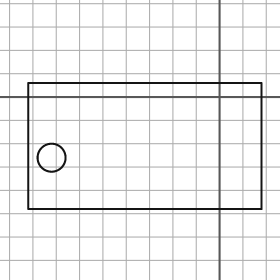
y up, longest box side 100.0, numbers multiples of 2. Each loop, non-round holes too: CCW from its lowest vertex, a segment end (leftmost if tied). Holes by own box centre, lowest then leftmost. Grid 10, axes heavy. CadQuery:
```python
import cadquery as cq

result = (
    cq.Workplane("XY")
    .moveTo(-82.0, -48.0)
    .lineTo(18.0, -48.0)
    .lineTo(18.0, 6.0)
    .lineTo(-82.0, 6.0)
    .close()
    .moveTo(-72.0, -26.0)
    .circle(6.0)
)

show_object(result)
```